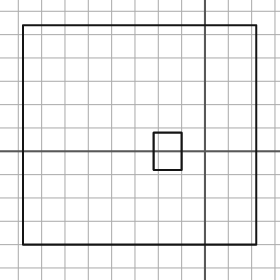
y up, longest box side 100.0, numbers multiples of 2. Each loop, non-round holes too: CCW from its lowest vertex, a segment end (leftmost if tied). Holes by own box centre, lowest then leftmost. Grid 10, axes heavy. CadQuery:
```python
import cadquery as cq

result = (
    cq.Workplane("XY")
    .moveTo(-78.0, -40.0)
    .lineTo(22.0, -40.0)
    .lineTo(22.0, 54.0)
    .lineTo(-78.0, 54.0)
    .close()
    .moveTo(-22.0, -8.0)
    .lineTo(-10.0, -8.0)
    .lineTo(-10.0, 8.0)
    .lineTo(-22.0, 8.0)
    .close()
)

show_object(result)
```